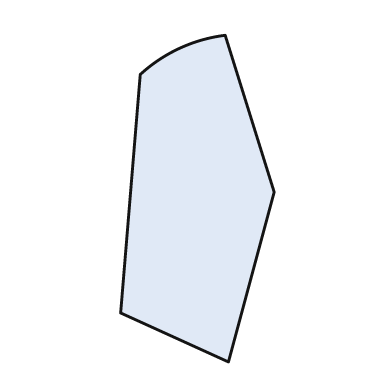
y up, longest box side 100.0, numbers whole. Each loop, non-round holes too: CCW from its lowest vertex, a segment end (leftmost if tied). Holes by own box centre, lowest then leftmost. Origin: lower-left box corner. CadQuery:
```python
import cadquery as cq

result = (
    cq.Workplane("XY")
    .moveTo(33.0, 0.0)
    .lineTo(47.0, 52.0)
    .lineTo(32.0, 100.0)
    .threePointArc((18.0, 96.0), (6.0, 88.0))
    .lineTo(0.0, 15.0)
    .close()
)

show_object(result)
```